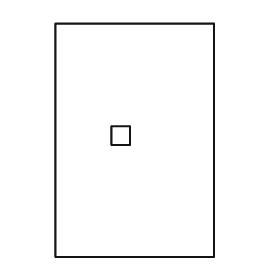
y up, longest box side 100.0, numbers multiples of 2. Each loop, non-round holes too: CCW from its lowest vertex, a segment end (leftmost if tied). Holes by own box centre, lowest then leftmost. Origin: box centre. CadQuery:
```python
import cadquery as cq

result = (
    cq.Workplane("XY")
    .moveTo(-34.0, -50.0)
    .lineTo(34.0, -50.0)
    .lineTo(34.0, 50.0)
    .lineTo(-34.0, 50.0)
    .close()
    .moveTo(-10.0, -2.0)
    .lineTo(-2.0, -2.0)
    .lineTo(-2.0, 6.0)
    .lineTo(-10.0, 6.0)
    .close()
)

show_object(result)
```